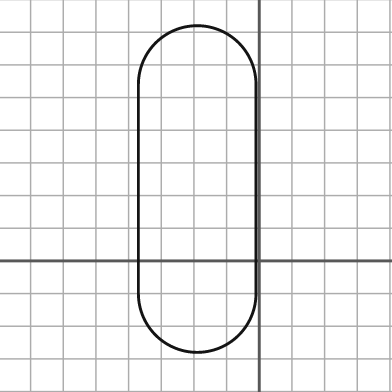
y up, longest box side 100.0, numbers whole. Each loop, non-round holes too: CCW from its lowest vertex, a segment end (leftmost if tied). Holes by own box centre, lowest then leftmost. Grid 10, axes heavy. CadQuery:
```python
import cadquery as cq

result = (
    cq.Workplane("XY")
    .moveTo(-37.0, -10.0)
    .threePointArc((-19.0, -28.0), (-1.0, -10.0))
    .lineTo(-1.0, 54.0)
    .threePointArc((-19.0, 72.0), (-37.0, 54.0))
    .close()
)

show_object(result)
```